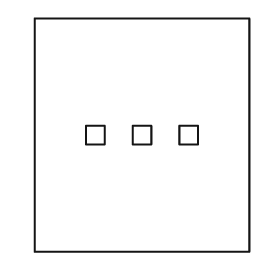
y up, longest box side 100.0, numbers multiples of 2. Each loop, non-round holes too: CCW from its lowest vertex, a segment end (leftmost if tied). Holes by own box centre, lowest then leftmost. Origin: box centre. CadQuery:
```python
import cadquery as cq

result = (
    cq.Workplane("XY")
    .moveTo(-46.0, -50.0)
    .lineTo(46.0, -50.0)
    .lineTo(46.0, 50.0)
    .lineTo(-46.0, 50.0)
    .close()
    .moveTo(-24.0, -4.0)
    .lineTo(-16.0, -4.0)
    .lineTo(-16.0, 4.0)
    .lineTo(-24.0, 4.0)
    .close()
    .moveTo(-4.0, -4.0)
    .lineTo(4.0, -4.0)
    .lineTo(4.0, 4.0)
    .lineTo(-4.0, 4.0)
    .close()
    .moveTo(16.0, -4.0)
    .lineTo(24.0, -4.0)
    .lineTo(24.0, 4.0)
    .lineTo(16.0, 4.0)
    .close()
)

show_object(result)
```